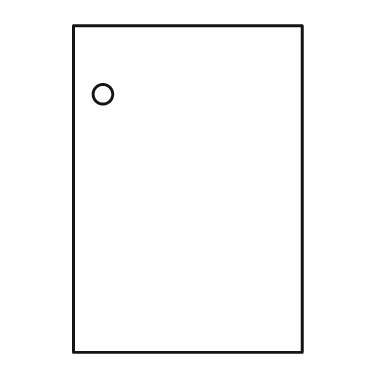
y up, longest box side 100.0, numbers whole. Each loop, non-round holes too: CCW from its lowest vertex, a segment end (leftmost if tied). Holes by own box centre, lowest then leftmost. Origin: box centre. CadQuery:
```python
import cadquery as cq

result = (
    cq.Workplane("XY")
    .moveTo(-35.0, -50.0)
    .lineTo(35.0, -50.0)
    .lineTo(35.0, 50.0)
    .lineTo(-35.0, 50.0)
    .close()
    .moveTo(-26.0, 29.0)
    .circle(3.0)
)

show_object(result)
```